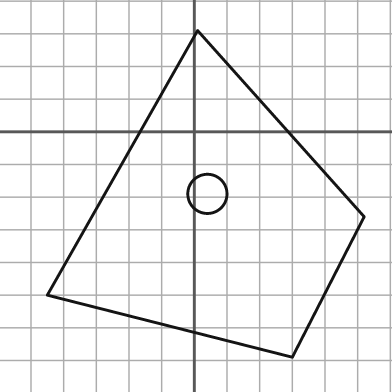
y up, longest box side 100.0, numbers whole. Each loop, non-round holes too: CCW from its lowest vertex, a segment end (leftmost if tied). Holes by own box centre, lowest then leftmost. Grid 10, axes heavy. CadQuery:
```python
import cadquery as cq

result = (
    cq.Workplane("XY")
    .moveTo(30.0, -69.0)
    .lineTo(52.0, -26.0)
    .lineTo(1.0, 31.0)
    .lineTo(-45.0, -50.0)
    .close()
    .moveTo(4.0, -19.0)
    .circle(6.0)
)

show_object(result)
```